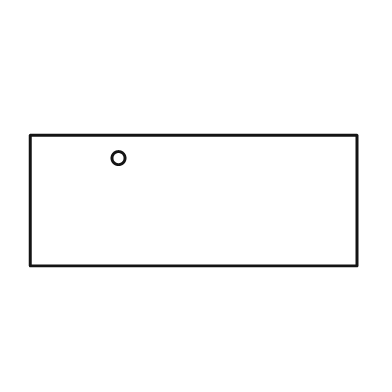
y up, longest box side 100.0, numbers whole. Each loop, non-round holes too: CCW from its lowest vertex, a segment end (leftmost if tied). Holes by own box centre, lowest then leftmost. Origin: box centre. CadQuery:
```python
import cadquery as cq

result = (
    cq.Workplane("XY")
    .moveTo(-50.0, -20.0)
    .lineTo(50.0, -20.0)
    .lineTo(50.0, 20.0)
    .lineTo(-50.0, 20.0)
    .close()
    .moveTo(-23.0, 13.0)
    .circle(2.0)
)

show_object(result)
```